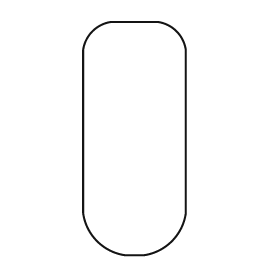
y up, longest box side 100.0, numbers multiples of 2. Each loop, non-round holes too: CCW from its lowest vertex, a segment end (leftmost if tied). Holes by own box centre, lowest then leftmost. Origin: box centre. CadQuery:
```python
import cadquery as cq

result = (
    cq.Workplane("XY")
    .moveTo(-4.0, -50.0)
    .lineTo(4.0, -50.0)
    .threePointArc((16.0, -44.0), (22.0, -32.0))
    .lineTo(22.0, 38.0)
    .threePointArc((18.0, 46.0), (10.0, 50.0))
    .lineTo(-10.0, 50.0)
    .threePointArc((-18.0, 46.0), (-22.0, 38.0))
    .lineTo(-22.0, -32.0)
    .threePointArc((-16.0, -44.0), (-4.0, -50.0))
    .close()
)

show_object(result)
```